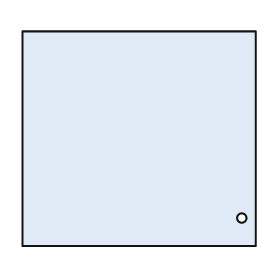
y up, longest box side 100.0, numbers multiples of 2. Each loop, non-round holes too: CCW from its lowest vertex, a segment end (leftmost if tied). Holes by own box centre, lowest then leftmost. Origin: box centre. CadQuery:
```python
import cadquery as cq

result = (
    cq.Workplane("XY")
    .moveTo(-50.0, -46.0)
    .lineTo(50.0, -46.0)
    .lineTo(50.0, 46.0)
    .lineTo(-50.0, 46.0)
    .close()
    .moveTo(44.0, -34.0)
    .circle(2.0)
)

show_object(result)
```